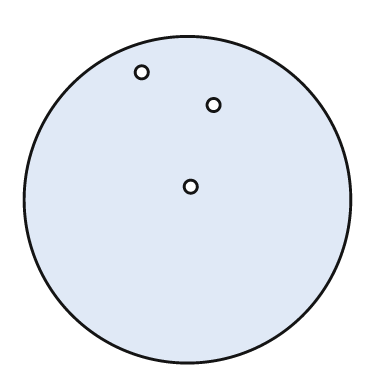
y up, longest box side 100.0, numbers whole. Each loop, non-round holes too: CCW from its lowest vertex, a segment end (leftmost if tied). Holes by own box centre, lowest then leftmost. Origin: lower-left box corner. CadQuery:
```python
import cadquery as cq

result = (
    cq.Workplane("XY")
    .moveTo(50.0, 50.0)
    .circle(50.0)
    .moveTo(51.0, 54.0)
    .circle(2.0)
    .moveTo(58.0, 79.0)
    .circle(2.0)
    .moveTo(36.0, 89.0)
    .circle(2.0)
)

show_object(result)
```